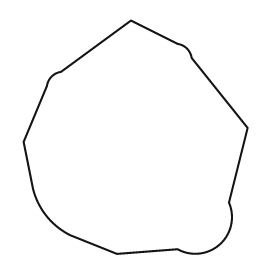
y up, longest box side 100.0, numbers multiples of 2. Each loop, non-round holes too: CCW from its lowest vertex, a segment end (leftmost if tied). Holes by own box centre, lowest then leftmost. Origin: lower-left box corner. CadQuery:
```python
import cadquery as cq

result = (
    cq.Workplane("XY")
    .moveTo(40.0, 0.0)
    .lineTo(66.0, 2.0)
    .threePointArc((84.0, 4.0), (88.0, 22.0))
    .lineTo(96.0, 54.0)
    .lineTo(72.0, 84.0)
    .threePointArc((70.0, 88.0), (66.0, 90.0))
    .lineTo(46.0, 100.0)
    .lineTo(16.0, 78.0)
    .threePointArc((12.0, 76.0), (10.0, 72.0))
    .lineTo(0.0, 48.0)
    .lineTo(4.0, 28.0)
    .threePointArc((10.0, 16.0), (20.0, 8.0))
    .close()
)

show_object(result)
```